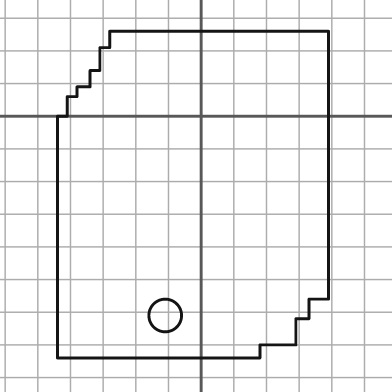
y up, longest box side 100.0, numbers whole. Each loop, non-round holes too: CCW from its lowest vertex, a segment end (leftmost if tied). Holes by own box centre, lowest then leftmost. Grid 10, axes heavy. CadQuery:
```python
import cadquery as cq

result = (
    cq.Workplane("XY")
    .moveTo(-44.0, -74.0)
    .lineTo(18.0, -74.0)
    .lineTo(18.0, -70.0)
    .lineTo(29.0, -70.0)
    .lineTo(29.0, -62.0)
    .lineTo(33.0, -62.0)
    .lineTo(33.0, -56.0)
    .lineTo(39.0, -56.0)
    .lineTo(39.0, 26.0)
    .lineTo(-28.0, 26.0)
    .lineTo(-28.0, 21.0)
    .lineTo(-31.0, 21.0)
    .lineTo(-31.0, 14.0)
    .lineTo(-34.0, 14.0)
    .lineTo(-34.0, 9.0)
    .lineTo(-38.0, 9.0)
    .lineTo(-38.0, 6.0)
    .lineTo(-41.0, 6.0)
    .lineTo(-41.0, 0.0)
    .lineTo(-44.0, 0.0)
    .close()
    .moveTo(-11.0, -61.0)
    .circle(5.0)
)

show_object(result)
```